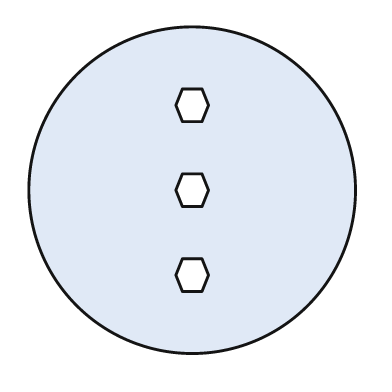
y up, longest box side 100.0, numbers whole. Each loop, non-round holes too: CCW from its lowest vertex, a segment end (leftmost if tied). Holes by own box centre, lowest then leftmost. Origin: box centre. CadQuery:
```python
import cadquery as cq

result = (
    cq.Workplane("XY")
    .moveTo(0.0, 0.0)
    .circle(50.0)
    .moveTo(-3.0, -31.0)
    .lineTo(3.0, -31.0)
    .lineTo(5.0, -26.0)
    .lineTo(3.0, -21.0)
    .lineTo(-3.0, -21.0)
    .lineTo(-5.0, -26.0)
    .close()
    .moveTo(-3.0, -5.0)
    .lineTo(3.0, -5.0)
    .lineTo(5.0, 0.0)
    .lineTo(3.0, 5.0)
    .lineTo(-3.0, 5.0)
    .lineTo(-5.0, 0.0)
    .close()
    .moveTo(-3.0, 21.0)
    .lineTo(3.0, 21.0)
    .lineTo(5.0, 26.0)
    .lineTo(3.0, 31.0)
    .lineTo(-3.0, 31.0)
    .lineTo(-5.0, 26.0)
    .close()
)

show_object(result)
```